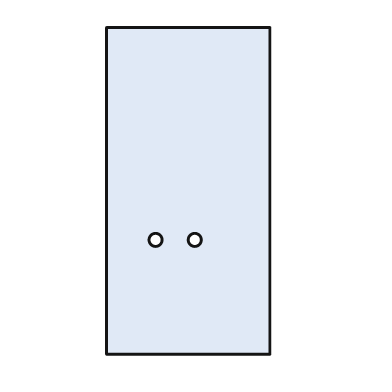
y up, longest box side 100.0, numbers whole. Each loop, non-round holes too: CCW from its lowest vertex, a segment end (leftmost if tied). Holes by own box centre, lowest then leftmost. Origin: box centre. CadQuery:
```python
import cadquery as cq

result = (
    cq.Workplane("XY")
    .moveTo(-25.0, -50.0)
    .lineTo(25.0, -50.0)
    .lineTo(25.0, 50.0)
    .lineTo(-25.0, 50.0)
    .close()
    .moveTo(-10.0, -15.0)
    .circle(2.0)
    .moveTo(2.0, -15.0)
    .circle(2.0)
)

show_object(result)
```